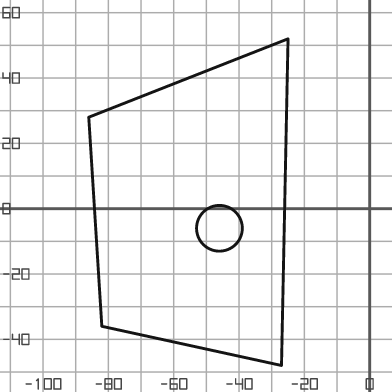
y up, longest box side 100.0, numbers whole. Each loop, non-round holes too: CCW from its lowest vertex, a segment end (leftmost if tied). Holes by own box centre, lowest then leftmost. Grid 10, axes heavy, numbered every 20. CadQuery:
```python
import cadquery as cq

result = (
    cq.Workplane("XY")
    .moveTo(-27.0, -48.0)
    .lineTo(-25.0, 52.0)
    .lineTo(-86.0, 28.0)
    .lineTo(-82.0, -36.0)
    .close()
    .moveTo(-46.0, -6.0)
    .circle(7.0)
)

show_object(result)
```